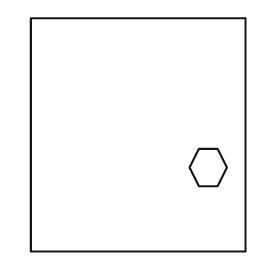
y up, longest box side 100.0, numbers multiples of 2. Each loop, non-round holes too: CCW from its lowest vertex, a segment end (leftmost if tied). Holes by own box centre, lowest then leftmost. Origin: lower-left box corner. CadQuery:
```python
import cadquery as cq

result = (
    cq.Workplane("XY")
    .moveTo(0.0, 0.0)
    .lineTo(92.0, 0.0)
    .lineTo(92.0, 100.0)
    .lineTo(0.0, 100.0)
    .close()
    .moveTo(72.0, 28.0)
    .lineTo(80.0, 28.0)
    .lineTo(84.0, 36.0)
    .lineTo(80.0, 44.0)
    .lineTo(72.0, 44.0)
    .lineTo(68.0, 36.0)
    .close()
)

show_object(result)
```